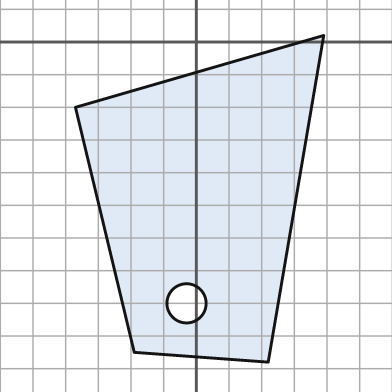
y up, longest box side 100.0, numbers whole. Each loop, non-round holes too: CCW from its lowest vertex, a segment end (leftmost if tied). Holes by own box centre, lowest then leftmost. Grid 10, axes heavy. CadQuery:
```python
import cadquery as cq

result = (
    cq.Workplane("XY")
    .moveTo(22.0, -98.0)
    .lineTo(39.0, 2.0)
    .lineTo(-37.0, -20.0)
    .lineTo(-19.0, -95.0)
    .close()
    .moveTo(-3.0, -80.0)
    .circle(6.0)
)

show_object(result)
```